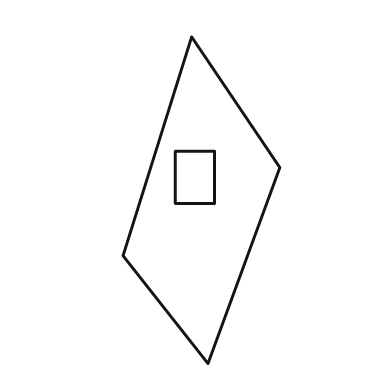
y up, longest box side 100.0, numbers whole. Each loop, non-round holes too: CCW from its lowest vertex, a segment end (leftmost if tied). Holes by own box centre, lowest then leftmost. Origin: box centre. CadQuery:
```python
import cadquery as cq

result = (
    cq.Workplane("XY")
    .moveTo(2.0, -50.0)
    .lineTo(24.0, 10.0)
    .lineTo(-3.0, 50.0)
    .lineTo(-24.0, -17.0)
    .close()
    .moveTo(-8.0, -1.0)
    .lineTo(4.0, -1.0)
    .lineTo(4.0, 15.0)
    .lineTo(-8.0, 15.0)
    .close()
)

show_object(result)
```